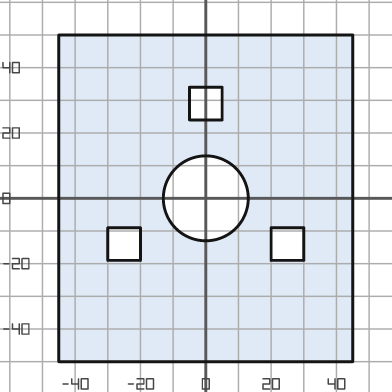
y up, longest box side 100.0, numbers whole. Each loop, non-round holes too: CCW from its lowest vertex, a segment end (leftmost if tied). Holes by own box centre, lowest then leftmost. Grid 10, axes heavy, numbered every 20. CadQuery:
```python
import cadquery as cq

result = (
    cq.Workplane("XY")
    .moveTo(-45.0, -50.0)
    .lineTo(45.0, -50.0)
    .lineTo(45.0, 50.0)
    .lineTo(-45.0, 50.0)
    .close()
    .moveTo(-30.0, -19.0)
    .lineTo(-20.0, -19.0)
    .lineTo(-20.0, -9.0)
    .lineTo(-30.0, -9.0)
    .close()
    .moveTo(20.0, -19.0)
    .lineTo(30.0, -19.0)
    .lineTo(30.0, -9.0)
    .lineTo(20.0, -9.0)
    .close()
    .moveTo(0.0, 0.0)
    .circle(13.0)
    .moveTo(-5.0, 24.0)
    .lineTo(5.0, 24.0)
    .lineTo(5.0, 34.0)
    .lineTo(-5.0, 34.0)
    .close()
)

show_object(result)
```